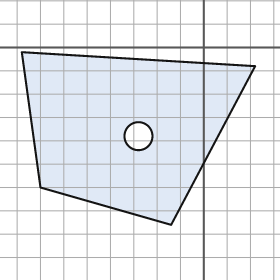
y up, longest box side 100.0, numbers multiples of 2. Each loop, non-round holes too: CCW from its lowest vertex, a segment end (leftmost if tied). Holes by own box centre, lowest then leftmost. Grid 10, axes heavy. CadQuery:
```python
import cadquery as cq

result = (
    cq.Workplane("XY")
    .moveTo(-14.0, -76.0)
    .lineTo(22.0, -8.0)
    .lineTo(-78.0, -2.0)
    .lineTo(-70.0, -60.0)
    .close()
    .moveTo(-28.0, -38.0)
    .circle(6.0)
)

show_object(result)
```